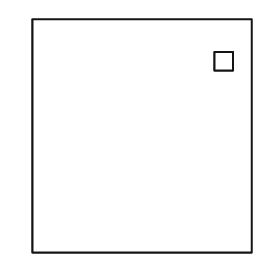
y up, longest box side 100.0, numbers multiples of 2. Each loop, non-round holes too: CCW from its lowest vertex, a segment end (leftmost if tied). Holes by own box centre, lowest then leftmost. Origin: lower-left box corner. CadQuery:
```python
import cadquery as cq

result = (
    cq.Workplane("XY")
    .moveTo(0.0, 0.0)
    .lineTo(94.0, 0.0)
    .lineTo(94.0, 100.0)
    .lineTo(0.0, 100.0)
    .close()
    .moveTo(78.0, 78.0)
    .lineTo(86.0, 78.0)
    .lineTo(86.0, 86.0)
    .lineTo(78.0, 86.0)
    .close()
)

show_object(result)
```